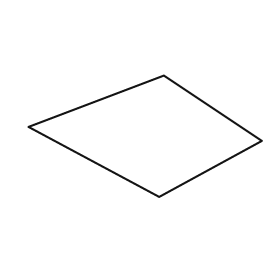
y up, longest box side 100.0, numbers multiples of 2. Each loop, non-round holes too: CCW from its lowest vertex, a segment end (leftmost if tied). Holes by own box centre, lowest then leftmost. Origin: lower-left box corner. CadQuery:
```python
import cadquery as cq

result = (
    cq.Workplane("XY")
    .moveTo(56.0, 0.0)
    .lineTo(100.0, 24.0)
    .lineTo(58.0, 52.0)
    .lineTo(0.0, 30.0)
    .close()
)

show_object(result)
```